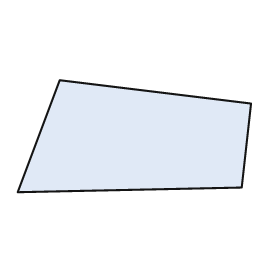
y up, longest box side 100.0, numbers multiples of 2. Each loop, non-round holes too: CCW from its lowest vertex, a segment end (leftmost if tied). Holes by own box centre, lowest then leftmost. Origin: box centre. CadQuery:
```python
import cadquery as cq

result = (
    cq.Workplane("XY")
    .moveTo(-50.0, -24.0)
    .lineTo(46.0, -22.0)
    .lineTo(50.0, 14.0)
    .lineTo(-32.0, 24.0)
    .close()
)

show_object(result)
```